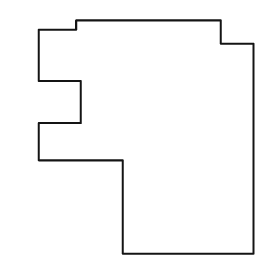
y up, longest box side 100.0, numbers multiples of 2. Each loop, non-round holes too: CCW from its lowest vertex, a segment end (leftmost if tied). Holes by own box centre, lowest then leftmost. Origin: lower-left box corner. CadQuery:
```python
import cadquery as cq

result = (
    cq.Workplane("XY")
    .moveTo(36.0, 0.0)
    .lineTo(92.0, 0.0)
    .lineTo(92.0, 90.0)
    .lineTo(78.0, 90.0)
    .lineTo(78.0, 100.0)
    .lineTo(16.0, 100.0)
    .lineTo(16.0, 96.0)
    .lineTo(0.0, 96.0)
    .lineTo(0.0, 74.0)
    .lineTo(18.0, 74.0)
    .lineTo(18.0, 56.0)
    .lineTo(0.0, 56.0)
    .lineTo(0.0, 40.0)
    .lineTo(36.0, 40.0)
    .close()
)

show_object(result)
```